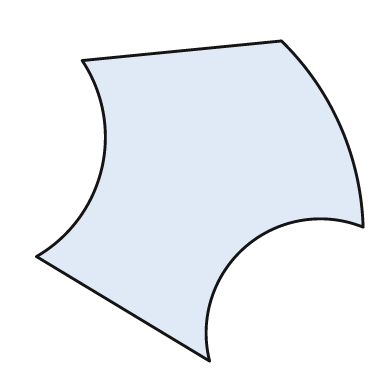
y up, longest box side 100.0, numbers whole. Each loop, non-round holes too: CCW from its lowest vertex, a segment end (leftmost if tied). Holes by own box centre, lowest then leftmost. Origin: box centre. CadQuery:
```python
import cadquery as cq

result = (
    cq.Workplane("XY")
    .moveTo(3.0, -49.0)
    .threePointArc((14.0, -14.0), (50.0, -8.0))
    .threePointArc((43.0, 23.0), (25.0, 49.0))
    .lineTo(-36.0, 43.0)
    .threePointArc((-30.0, 10.0), (-50.0, -17.0))
    .close()
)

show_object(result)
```